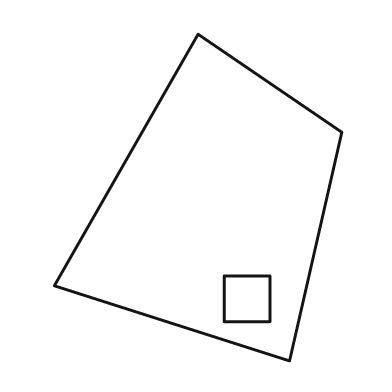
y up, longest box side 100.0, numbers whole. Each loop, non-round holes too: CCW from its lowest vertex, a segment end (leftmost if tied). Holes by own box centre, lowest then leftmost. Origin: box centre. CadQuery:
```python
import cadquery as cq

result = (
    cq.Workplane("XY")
    .moveTo(28.0, -50.0)
    .lineTo(44.0, 20.0)
    .lineTo(0.0, 50.0)
    .lineTo(-44.0, -27.0)
    .close()
    .moveTo(8.0, -38.0)
    .lineTo(22.0, -38.0)
    .lineTo(22.0, -24.0)
    .lineTo(8.0, -24.0)
    .close()
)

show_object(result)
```